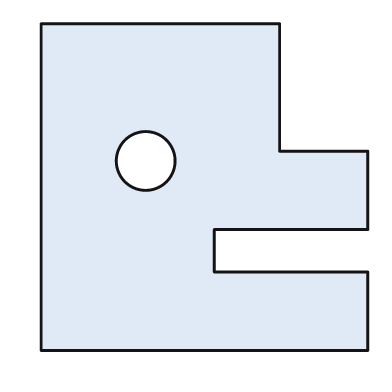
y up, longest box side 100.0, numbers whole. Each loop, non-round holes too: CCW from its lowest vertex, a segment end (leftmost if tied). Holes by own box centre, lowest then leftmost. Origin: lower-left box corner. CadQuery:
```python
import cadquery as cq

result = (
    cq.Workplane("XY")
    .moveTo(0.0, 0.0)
    .lineTo(100.0, 0.0)
    .lineTo(100.0, 24.0)
    .lineTo(53.0, 24.0)
    .lineTo(53.0, 37.0)
    .lineTo(100.0, 37.0)
    .lineTo(100.0, 61.0)
    .lineTo(73.0, 61.0)
    .lineTo(73.0, 100.0)
    .lineTo(0.0, 100.0)
    .close()
    .moveTo(32.0, 58.0)
    .circle(9.0)
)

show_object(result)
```